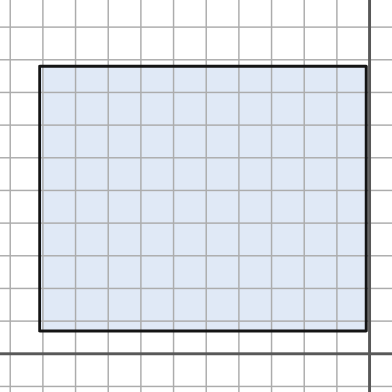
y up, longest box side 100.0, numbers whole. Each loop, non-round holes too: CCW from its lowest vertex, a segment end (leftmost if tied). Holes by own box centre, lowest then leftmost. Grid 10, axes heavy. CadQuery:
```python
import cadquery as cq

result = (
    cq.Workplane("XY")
    .moveTo(-101.0, 7.0)
    .lineTo(-1.0, 7.0)
    .lineTo(-1.0, 88.0)
    .lineTo(-101.0, 88.0)
    .close()
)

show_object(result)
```